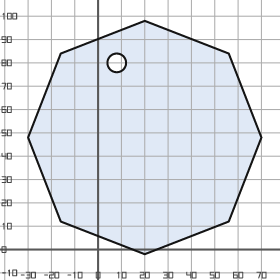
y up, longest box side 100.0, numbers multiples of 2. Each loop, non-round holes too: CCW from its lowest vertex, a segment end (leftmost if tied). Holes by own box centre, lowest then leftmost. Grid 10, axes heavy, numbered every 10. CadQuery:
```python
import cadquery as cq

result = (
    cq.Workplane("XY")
    .moveTo(20.0, -2.0)
    .lineTo(56.0, 12.0)
    .lineTo(70.0, 48.0)
    .lineTo(56.0, 84.0)
    .lineTo(20.0, 98.0)
    .lineTo(-16.0, 84.0)
    .lineTo(-30.0, 48.0)
    .lineTo(-16.0, 12.0)
    .close()
    .moveTo(8.0, 80.0)
    .circle(4.0)
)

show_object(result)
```